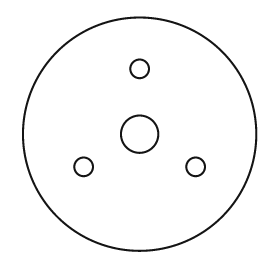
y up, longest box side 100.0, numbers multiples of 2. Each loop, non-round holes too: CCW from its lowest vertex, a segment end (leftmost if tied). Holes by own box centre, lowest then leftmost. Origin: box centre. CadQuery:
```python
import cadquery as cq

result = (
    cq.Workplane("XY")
    .moveTo(0.0, 0.0)
    .circle(50.0)
    .moveTo(-24.0, -14.0)
    .circle(4.0)
    .moveTo(24.0, -14.0)
    .circle(4.0)
    .moveTo(0.0, 0.0)
    .circle(8.0)
    .moveTo(0.0, 28.0)
    .circle(4.0)
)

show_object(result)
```